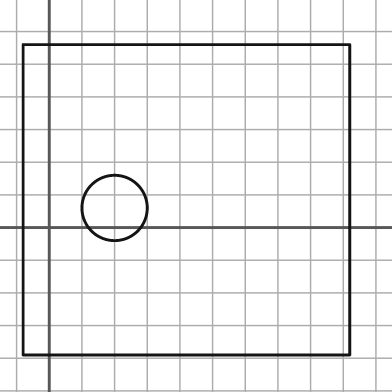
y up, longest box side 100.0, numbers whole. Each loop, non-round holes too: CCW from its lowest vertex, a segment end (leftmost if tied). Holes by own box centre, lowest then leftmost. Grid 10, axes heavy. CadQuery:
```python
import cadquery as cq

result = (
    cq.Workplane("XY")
    .moveTo(-8.0, -39.0)
    .lineTo(92.0, -39.0)
    .lineTo(92.0, 56.0)
    .lineTo(-8.0, 56.0)
    .close()
    .moveTo(20.0, 6.0)
    .circle(10.0)
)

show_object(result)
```